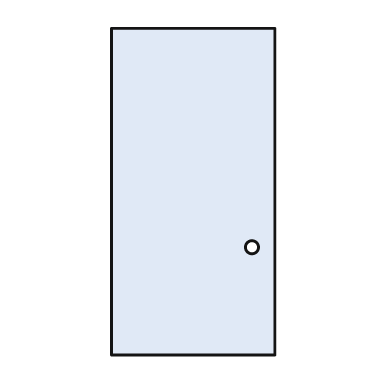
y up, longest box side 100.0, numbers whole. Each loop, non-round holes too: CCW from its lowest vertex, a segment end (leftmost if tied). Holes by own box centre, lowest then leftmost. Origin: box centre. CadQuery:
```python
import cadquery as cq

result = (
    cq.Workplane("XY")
    .moveTo(-25.0, -50.0)
    .lineTo(25.0, -50.0)
    .lineTo(25.0, 50.0)
    .lineTo(-25.0, 50.0)
    .close()
    .moveTo(18.0, -17.0)
    .circle(2.0)
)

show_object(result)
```